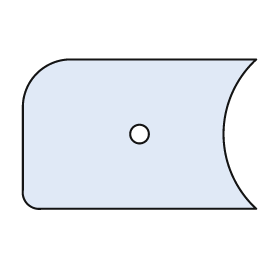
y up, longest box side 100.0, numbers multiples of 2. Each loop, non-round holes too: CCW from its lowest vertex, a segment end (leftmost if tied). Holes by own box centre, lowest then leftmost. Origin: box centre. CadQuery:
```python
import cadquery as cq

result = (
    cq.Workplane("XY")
    .moveTo(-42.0, -32.0)
    .lineTo(50.0, -32.0)
    .threePointArc((36.0, 0.0), (50.0, 32.0))
    .lineTo(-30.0, 32.0)
    .threePointArc((-44.0, 26.0), (-50.0, 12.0))
    .lineTo(-50.0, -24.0)
    .threePointArc((-48.0, -30.0), (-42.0, -32.0))
    .close()
    .moveTo(0.0, 0.0)
    .circle(4.0)
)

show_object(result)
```